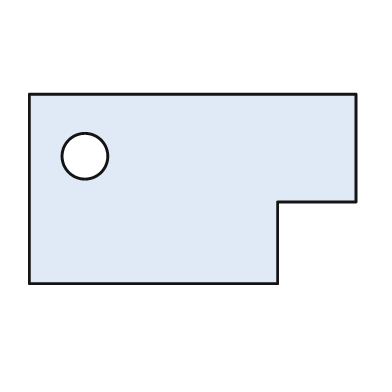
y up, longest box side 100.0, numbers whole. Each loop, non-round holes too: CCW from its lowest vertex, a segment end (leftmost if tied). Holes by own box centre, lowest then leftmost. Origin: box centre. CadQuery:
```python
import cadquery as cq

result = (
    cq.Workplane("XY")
    .moveTo(-50.0, -29.0)
    .lineTo(26.0, -29.0)
    .lineTo(26.0, -4.0)
    .lineTo(50.0, -4.0)
    .lineTo(50.0, 29.0)
    .lineTo(-50.0, 29.0)
    .close()
    .moveTo(-33.0, 10.0)
    .circle(7.0)
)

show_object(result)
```